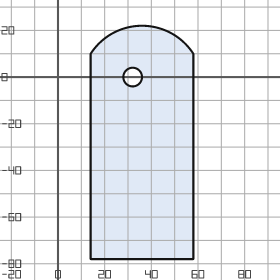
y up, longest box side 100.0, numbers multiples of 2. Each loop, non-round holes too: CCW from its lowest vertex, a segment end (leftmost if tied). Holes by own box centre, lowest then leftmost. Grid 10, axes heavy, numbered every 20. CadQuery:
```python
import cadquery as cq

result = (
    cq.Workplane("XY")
    .moveTo(14.0, -78.0)
    .lineTo(58.0, -78.0)
    .lineTo(58.0, 10.0)
    .threePointArc((36.0, 22.0), (14.0, 10.0))
    .close()
    .moveTo(32.0, 0.0)
    .circle(4.0)
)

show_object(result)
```